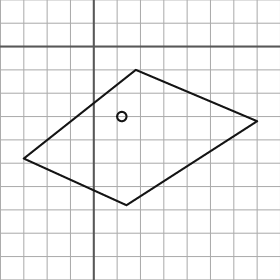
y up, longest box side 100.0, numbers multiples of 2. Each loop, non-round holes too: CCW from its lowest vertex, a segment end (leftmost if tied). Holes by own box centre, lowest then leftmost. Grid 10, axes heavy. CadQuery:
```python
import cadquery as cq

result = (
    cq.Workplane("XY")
    .moveTo(14.0, -68.0)
    .lineTo(70.0, -32.0)
    .lineTo(18.0, -10.0)
    .lineTo(-30.0, -48.0)
    .close()
    .moveTo(12.0, -30.0)
    .circle(2.0)
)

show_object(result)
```